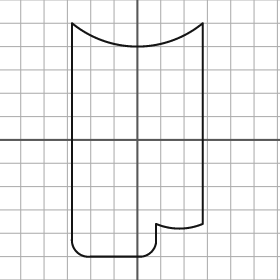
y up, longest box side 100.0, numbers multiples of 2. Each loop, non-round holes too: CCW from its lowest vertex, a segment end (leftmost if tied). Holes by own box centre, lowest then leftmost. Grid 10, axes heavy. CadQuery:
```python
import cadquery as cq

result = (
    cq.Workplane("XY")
    .moveTo(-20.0, -50.0)
    .lineTo(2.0, -50.0)
    .threePointArc((6.0, -48.0), (8.0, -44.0))
    .lineTo(8.0, -36.0)
    .threePointArc((18.0, -38.0), (28.0, -36.0))
    .lineTo(28.0, 50.0)
    .threePointArc((0.0, 40.0), (-28.0, 50.0))
    .lineTo(-28.0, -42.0)
    .threePointArc((-26.0, -48.0), (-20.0, -50.0))
    .close()
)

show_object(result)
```